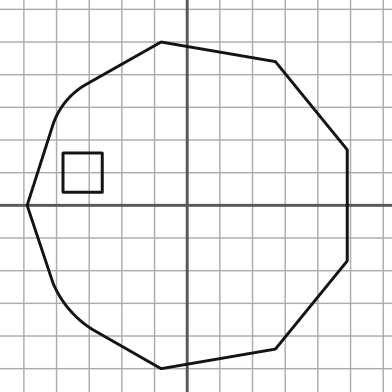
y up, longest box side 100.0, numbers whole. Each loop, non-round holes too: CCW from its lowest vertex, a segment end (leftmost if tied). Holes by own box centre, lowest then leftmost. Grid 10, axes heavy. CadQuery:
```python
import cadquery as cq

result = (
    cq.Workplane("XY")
    .moveTo(-8.0, -50.0)
    .lineTo(27.0, -44.0)
    .lineTo(49.0, -17.0)
    .lineTo(49.0, 17.0)
    .lineTo(27.0, 44.0)
    .lineTo(-8.0, 50.0)
    .lineTo(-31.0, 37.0)
    .threePointArc((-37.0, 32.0), (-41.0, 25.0))
    .lineTo(-49.0, 0.0)
    .lineTo(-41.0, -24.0)
    .threePointArc((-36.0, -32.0), (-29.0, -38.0))
    .close()
    .moveTo(-38.0, 4.0)
    .lineTo(-26.0, 4.0)
    .lineTo(-26.0, 16.0)
    .lineTo(-38.0, 16.0)
    .close()
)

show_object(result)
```